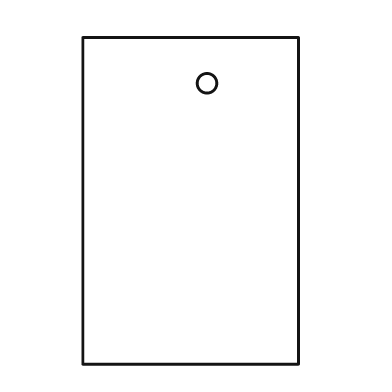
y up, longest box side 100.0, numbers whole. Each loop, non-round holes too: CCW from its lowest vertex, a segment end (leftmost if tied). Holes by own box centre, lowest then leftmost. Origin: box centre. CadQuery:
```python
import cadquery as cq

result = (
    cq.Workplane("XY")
    .moveTo(-33.0, -50.0)
    .lineTo(33.0, -50.0)
    .lineTo(33.0, 50.0)
    .lineTo(-33.0, 50.0)
    .close()
    .moveTo(5.0, 36.0)
    .circle(3.0)
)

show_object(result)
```